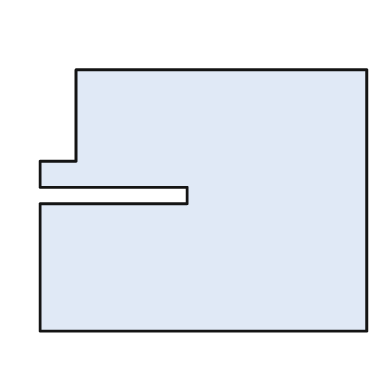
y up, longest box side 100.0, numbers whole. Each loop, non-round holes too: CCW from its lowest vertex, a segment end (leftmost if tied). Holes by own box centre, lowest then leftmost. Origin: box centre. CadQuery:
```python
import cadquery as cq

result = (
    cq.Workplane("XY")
    .moveTo(-50.0, -40.0)
    .lineTo(50.0, -40.0)
    .lineTo(50.0, 40.0)
    .lineTo(-39.0, 40.0)
    .lineTo(-39.0, 12.0)
    .lineTo(-50.0, 12.0)
    .lineTo(-50.0, 4.0)
    .lineTo(-5.0, 4.0)
    .lineTo(-5.0, -1.0)
    .lineTo(-50.0, -1.0)
    .close()
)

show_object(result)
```